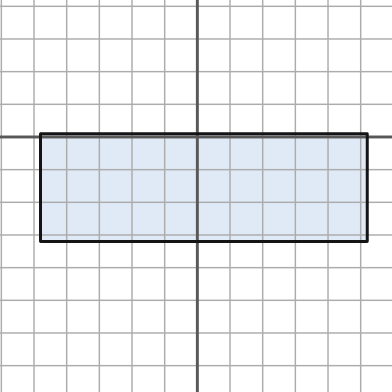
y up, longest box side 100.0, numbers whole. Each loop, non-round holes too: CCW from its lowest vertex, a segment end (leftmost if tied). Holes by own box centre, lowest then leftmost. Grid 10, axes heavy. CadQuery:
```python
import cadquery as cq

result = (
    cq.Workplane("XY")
    .moveTo(-48.0, -32.0)
    .lineTo(52.0, -32.0)
    .lineTo(52.0, 1.0)
    .lineTo(-48.0, 1.0)
    .close()
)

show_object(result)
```